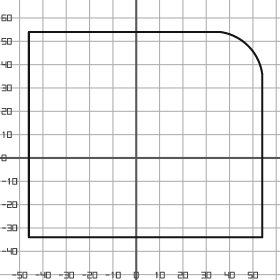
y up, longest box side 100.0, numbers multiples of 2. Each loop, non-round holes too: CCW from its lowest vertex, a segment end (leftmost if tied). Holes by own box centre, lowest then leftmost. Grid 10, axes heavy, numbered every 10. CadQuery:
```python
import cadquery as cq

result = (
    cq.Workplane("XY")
    .moveTo(-46.0, -34.0)
    .lineTo(54.0, -34.0)
    .lineTo(54.0, 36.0)
    .threePointArc((48.0, 48.0), (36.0, 54.0))
    .lineTo(-46.0, 54.0)
    .close()
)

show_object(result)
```